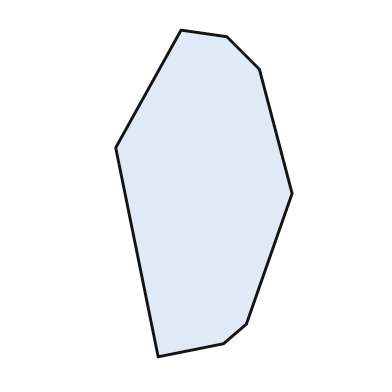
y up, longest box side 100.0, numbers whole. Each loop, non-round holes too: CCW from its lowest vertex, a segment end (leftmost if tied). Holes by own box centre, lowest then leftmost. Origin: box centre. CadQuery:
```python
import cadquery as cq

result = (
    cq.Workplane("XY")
    .moveTo(-14.0, -50.0)
    .lineTo(6.0, -46.0)
    .lineTo(13.0, -40.0)
    .lineTo(27.0, 0.0)
    .lineTo(17.0, 38.0)
    .lineTo(7.0, 48.0)
    .lineTo(-7.0, 50.0)
    .lineTo(-27.0, 14.0)
    .close()
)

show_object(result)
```